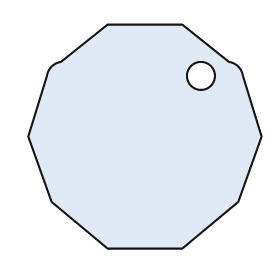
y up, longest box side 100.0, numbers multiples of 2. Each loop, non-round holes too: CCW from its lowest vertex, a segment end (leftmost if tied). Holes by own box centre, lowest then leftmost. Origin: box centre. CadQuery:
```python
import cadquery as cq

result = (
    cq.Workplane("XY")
    .moveTo(-16.0, -48.0)
    .lineTo(16.0, -48.0)
    .lineTo(40.0, -28.0)
    .lineTo(50.0, 0.0)
    .lineTo(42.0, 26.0)
    .threePointArc((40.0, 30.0), (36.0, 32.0))
    .lineTo(16.0, 48.0)
    .lineTo(-16.0, 48.0)
    .lineTo(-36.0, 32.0)
    .threePointArc((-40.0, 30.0), (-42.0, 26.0))
    .lineTo(-50.0, 0.0)
    .lineTo(-40.0, -28.0)
    .close()
    .moveTo(24.0, 26.0)
    .circle(6.0)
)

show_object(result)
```